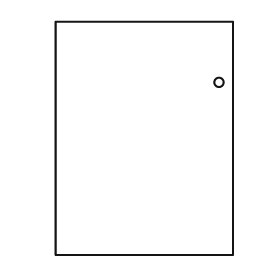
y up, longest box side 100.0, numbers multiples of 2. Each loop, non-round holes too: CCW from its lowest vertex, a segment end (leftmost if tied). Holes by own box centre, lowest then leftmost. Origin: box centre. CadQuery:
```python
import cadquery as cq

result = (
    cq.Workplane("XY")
    .moveTo(-38.0, -50.0)
    .lineTo(38.0, -50.0)
    .lineTo(38.0, 50.0)
    .lineTo(-38.0, 50.0)
    .close()
    .moveTo(32.0, 24.0)
    .circle(2.0)
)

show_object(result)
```